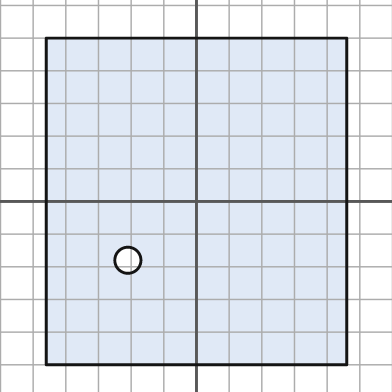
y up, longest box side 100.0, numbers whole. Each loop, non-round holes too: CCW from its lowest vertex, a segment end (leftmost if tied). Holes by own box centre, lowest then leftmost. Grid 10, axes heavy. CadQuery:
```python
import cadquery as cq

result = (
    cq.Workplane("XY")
    .moveTo(-46.0, -50.0)
    .lineTo(46.0, -50.0)
    .lineTo(46.0, 50.0)
    .lineTo(-46.0, 50.0)
    .close()
    .moveTo(-21.0, -18.0)
    .circle(4.0)
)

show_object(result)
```